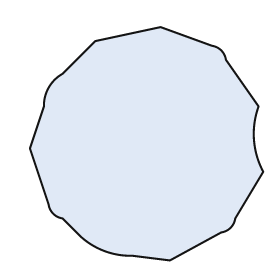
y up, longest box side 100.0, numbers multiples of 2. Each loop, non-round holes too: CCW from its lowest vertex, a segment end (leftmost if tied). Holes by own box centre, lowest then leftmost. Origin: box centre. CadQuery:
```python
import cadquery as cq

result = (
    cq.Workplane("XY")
    .moveTo(10.0, -50.0)
    .lineTo(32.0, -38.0)
    .threePointArc((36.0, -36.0), (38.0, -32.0))
    .lineTo(50.0, -12.0)
    .threePointArc((46.0, 2.0), (48.0, 16.0))
    .lineTo(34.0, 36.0)
    .threePointArc((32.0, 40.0), (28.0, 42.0))
    .lineTo(6.0, 50.0)
    .lineTo(-22.0, 44.0)
    .lineTo(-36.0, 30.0)
    .threePointArc((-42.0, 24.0), (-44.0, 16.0))
    .lineTo(-50.0, -2.0)
    .lineTo(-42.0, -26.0)
    .threePointArc((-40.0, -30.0), (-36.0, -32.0))
    .lineTo(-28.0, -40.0)
    .threePointArc((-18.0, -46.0), (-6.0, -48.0))
    .close()
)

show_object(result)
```